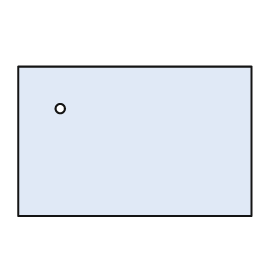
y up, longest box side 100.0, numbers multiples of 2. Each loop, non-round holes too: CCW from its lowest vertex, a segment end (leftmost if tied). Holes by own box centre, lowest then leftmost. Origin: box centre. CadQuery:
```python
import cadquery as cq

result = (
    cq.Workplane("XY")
    .moveTo(-50.0, -32.0)
    .lineTo(50.0, -32.0)
    .lineTo(50.0, 32.0)
    .lineTo(-50.0, 32.0)
    .close()
    .moveTo(-32.0, 14.0)
    .circle(2.0)
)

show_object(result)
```